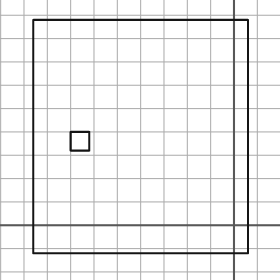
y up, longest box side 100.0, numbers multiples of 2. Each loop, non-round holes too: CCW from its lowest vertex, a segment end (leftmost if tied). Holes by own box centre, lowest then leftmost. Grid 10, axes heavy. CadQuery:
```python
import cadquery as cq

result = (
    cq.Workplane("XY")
    .moveTo(-86.0, -12.0)
    .lineTo(6.0, -12.0)
    .lineTo(6.0, 88.0)
    .lineTo(-86.0, 88.0)
    .close()
    .moveTo(-70.0, 32.0)
    .lineTo(-62.0, 32.0)
    .lineTo(-62.0, 40.0)
    .lineTo(-70.0, 40.0)
    .close()
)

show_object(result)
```